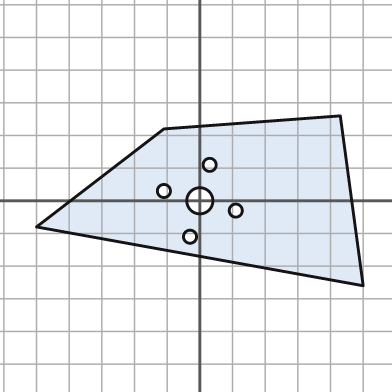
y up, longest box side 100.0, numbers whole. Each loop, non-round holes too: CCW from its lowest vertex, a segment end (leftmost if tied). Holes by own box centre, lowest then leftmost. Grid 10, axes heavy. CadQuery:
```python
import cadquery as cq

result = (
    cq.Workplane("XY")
    .moveTo(50.0, -26.0)
    .lineTo(43.0, 26.0)
    .lineTo(-11.0, 22.0)
    .lineTo(-50.0, -8.0)
    .close()
    .moveTo(-3.0, -11.0)
    .circle(2.0)
    .moveTo(11.0, -3.0)
    .circle(2.0)
    .moveTo(0.0, 0.0)
    .circle(4.0)
    .moveTo(-11.0, 3.0)
    .circle(2.0)
    .moveTo(3.0, 11.0)
    .circle(2.0)
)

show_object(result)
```